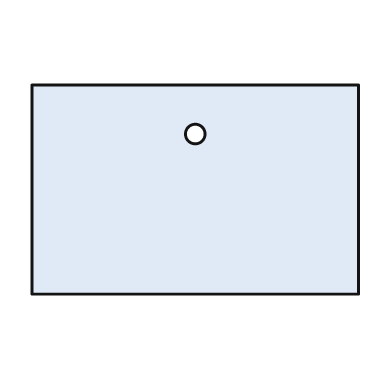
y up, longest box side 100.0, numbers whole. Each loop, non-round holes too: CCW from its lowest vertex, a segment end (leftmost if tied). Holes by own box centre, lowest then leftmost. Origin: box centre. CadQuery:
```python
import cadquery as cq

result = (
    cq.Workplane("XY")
    .moveTo(-50.0, -32.0)
    .lineTo(50.0, -32.0)
    .lineTo(50.0, 32.0)
    .lineTo(-50.0, 32.0)
    .close()
    .moveTo(0.0, 17.0)
    .circle(3.0)
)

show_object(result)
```